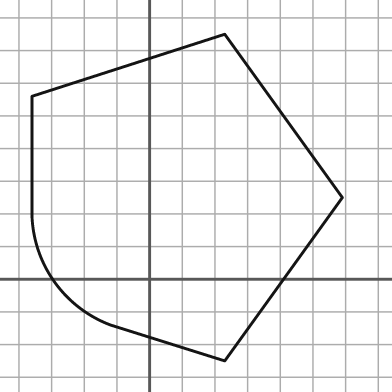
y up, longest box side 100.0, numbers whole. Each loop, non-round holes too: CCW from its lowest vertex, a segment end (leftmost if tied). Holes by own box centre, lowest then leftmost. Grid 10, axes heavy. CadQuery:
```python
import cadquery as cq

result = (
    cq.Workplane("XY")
    .moveTo(23.0, -25.0)
    .lineTo(59.0, 25.0)
    .lineTo(23.0, 75.0)
    .lineTo(-36.0, 56.0)
    .lineTo(-36.0, 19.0)
    .threePointArc((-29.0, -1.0), (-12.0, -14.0))
    .close()
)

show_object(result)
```